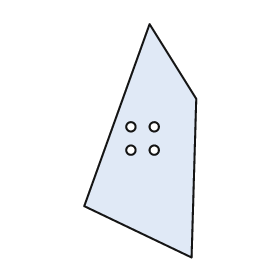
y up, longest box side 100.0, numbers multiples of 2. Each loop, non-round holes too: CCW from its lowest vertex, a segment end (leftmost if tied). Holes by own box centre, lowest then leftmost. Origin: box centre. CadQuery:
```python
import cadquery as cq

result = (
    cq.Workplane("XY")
    .moveTo(22.0, -50.0)
    .lineTo(24.0, 18.0)
    .lineTo(4.0, 50.0)
    .lineTo(-24.0, -28.0)
    .close()
    .moveTo(-4.0, -4.0)
    .circle(2.0)
    .moveTo(6.0, -4.0)
    .circle(2.0)
    .moveTo(-4.0, 6.0)
    .circle(2.0)
    .moveTo(6.0, 6.0)
    .circle(2.0)
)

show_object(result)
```